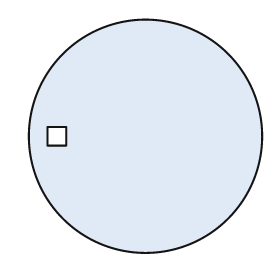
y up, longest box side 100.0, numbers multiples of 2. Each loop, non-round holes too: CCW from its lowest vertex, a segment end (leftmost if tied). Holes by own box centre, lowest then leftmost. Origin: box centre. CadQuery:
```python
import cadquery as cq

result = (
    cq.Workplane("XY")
    .moveTo(0.0, 0.0)
    .circle(50.0)
    .moveTo(-42.0, -4.0)
    .lineTo(-34.0, -4.0)
    .lineTo(-34.0, 4.0)
    .lineTo(-42.0, 4.0)
    .close()
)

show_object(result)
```